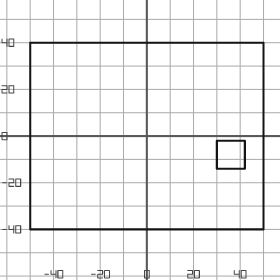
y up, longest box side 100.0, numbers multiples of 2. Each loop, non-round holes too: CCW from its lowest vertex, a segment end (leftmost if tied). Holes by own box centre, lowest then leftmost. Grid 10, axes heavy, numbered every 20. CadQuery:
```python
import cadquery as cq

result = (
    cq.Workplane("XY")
    .moveTo(-50.0, -40.0)
    .lineTo(50.0, -40.0)
    .lineTo(50.0, 40.0)
    .lineTo(-50.0, 40.0)
    .close()
    .moveTo(30.0, -14.0)
    .lineTo(42.0, -14.0)
    .lineTo(42.0, -2.0)
    .lineTo(30.0, -2.0)
    .close()
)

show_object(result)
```